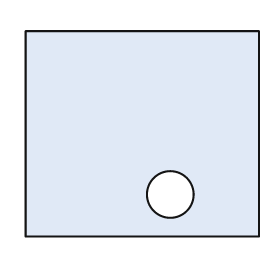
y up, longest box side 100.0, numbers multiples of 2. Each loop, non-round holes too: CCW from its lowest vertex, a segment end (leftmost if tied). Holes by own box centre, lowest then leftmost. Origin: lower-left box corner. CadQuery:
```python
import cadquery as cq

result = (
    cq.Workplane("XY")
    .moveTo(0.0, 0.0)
    .lineTo(100.0, 0.0)
    .lineTo(100.0, 88.0)
    .lineTo(0.0, 88.0)
    .close()
    .moveTo(62.0, 18.0)
    .circle(10.0)
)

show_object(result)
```